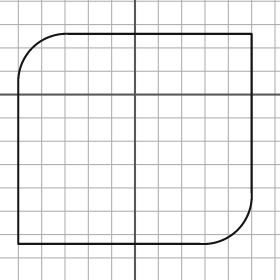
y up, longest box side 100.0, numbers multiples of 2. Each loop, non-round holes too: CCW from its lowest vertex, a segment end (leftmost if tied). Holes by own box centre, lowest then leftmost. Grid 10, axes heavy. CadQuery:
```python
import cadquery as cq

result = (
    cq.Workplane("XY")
    .moveTo(-50.0, -64.0)
    .lineTo(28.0, -64.0)
    .threePointArc((44.0, -58.0), (50.0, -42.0))
    .lineTo(50.0, 26.0)
    .lineTo(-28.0, 26.0)
    .threePointArc((-44.0, 20.0), (-50.0, 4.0))
    .close()
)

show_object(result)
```